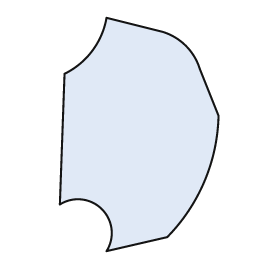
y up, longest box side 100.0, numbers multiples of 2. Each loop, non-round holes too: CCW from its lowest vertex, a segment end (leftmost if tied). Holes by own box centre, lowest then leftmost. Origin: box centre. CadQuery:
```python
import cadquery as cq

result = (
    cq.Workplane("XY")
    .moveTo(-14.0, -50.0)
    .lineTo(12.0, -44.0)
    .threePointArc((28.0, -20.0), (34.0, 8.0))
    .lineTo(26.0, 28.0)
    .threePointArc((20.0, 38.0), (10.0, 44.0))
    .lineTo(-14.0, 50.0)
    .threePointArc((-20.0, 36.0), (-32.0, 26.0))
    .lineTo(-34.0, -30.0)
    .threePointArc((-16.0, -32.0), (-14.0, -50.0))
    .close()
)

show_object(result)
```